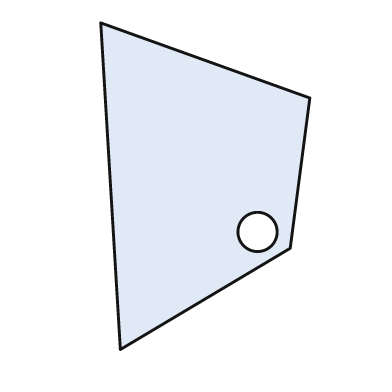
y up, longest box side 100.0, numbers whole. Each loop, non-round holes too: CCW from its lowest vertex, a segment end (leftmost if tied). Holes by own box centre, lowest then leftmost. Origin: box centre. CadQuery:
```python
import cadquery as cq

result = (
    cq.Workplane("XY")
    .moveTo(-26.0, -50.0)
    .lineTo(26.0, -19.0)
    .lineTo(32.0, 27.0)
    .lineTo(-32.0, 50.0)
    .close()
    .moveTo(16.0, -14.0)
    .circle(6.0)
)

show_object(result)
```